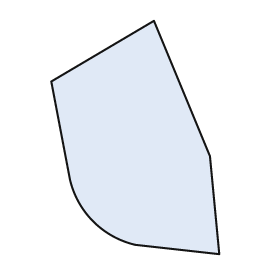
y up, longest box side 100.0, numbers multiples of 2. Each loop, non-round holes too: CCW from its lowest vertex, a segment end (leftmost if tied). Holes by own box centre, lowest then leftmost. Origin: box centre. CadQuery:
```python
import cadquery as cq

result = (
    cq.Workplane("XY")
    .moveTo(36.0, -50.0)
    .lineTo(32.0, -8.0)
    .lineTo(8.0, 50.0)
    .lineTo(-36.0, 24.0)
    .lineTo(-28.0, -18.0)
    .threePointArc((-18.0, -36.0), (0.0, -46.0))
    .close()
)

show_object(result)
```